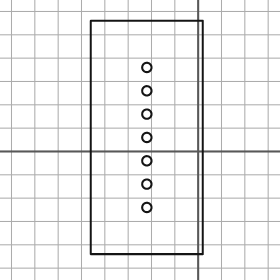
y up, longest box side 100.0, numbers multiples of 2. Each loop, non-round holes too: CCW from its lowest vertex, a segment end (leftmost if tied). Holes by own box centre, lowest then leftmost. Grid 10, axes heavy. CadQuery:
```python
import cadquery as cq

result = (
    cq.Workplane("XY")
    .moveTo(-46.0, -44.0)
    .lineTo(2.0, -44.0)
    .lineTo(2.0, 56.0)
    .lineTo(-46.0, 56.0)
    .close()
    .moveTo(-22.0, -24.0)
    .circle(2.0)
    .moveTo(-22.0, -14.0)
    .circle(2.0)
    .moveTo(-22.0, -4.0)
    .circle(2.0)
    .moveTo(-22.0, 6.0)
    .circle(2.0)
    .moveTo(-22.0, 16.0)
    .circle(2.0)
    .moveTo(-22.0, 26.0)
    .circle(2.0)
    .moveTo(-22.0, 36.0)
    .circle(2.0)
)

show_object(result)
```